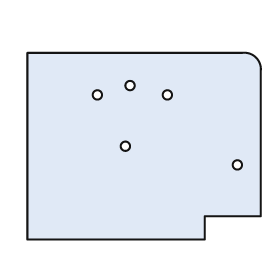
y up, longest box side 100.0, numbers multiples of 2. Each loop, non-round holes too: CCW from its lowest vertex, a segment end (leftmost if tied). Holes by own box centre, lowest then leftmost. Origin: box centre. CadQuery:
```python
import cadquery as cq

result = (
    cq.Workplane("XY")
    .moveTo(-50.0, -40.0)
    .lineTo(26.0, -40.0)
    .lineTo(26.0, -30.0)
    .lineTo(50.0, -30.0)
    .lineTo(50.0, 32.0)
    .threePointArc((48.0, 38.0), (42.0, 40.0))
    .lineTo(-50.0, 40.0)
    .close()
    .moveTo(40.0, -8.0)
    .circle(2.0)
    .moveTo(-8.0, 0.0)
    .circle(2.0)
    .moveTo(-20.0, 22.0)
    .circle(2.0)
    .moveTo(10.0, 22.0)
    .circle(2.0)
    .moveTo(-6.0, 26.0)
    .circle(2.0)
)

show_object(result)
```